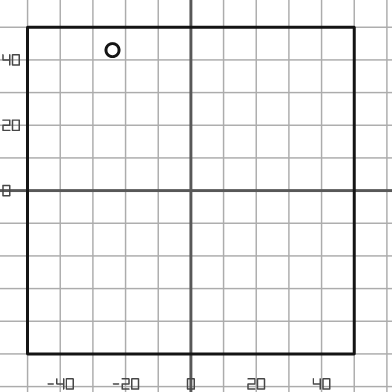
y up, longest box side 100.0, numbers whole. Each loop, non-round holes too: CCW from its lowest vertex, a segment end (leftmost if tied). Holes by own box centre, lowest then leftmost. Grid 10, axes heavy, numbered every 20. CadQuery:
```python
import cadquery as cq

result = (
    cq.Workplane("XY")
    .moveTo(-50.0, -50.0)
    .lineTo(50.0, -50.0)
    .lineTo(50.0, 50.0)
    .lineTo(-50.0, 50.0)
    .close()
    .moveTo(-24.0, 43.0)
    .circle(2.0)
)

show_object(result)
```